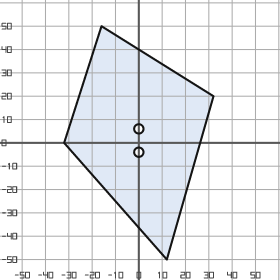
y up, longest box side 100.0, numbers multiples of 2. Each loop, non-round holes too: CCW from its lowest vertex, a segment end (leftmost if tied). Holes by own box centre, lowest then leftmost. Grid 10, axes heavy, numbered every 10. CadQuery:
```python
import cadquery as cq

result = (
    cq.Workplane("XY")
    .moveTo(12.0, -50.0)
    .lineTo(32.0, 20.0)
    .lineTo(-16.0, 50.0)
    .lineTo(-32.0, 0.0)
    .close()
    .moveTo(0.0, -4.0)
    .circle(2.0)
    .moveTo(0.0, 6.0)
    .circle(2.0)
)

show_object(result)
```